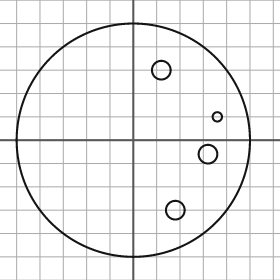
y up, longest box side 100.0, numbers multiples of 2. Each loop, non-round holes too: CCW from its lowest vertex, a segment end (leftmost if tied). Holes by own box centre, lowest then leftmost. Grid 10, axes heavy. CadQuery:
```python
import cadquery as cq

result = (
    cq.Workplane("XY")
    .moveTo(0.0, 0.0)
    .circle(50.0)
    .moveTo(18.0, -30.0)
    .circle(4.0)
    .moveTo(32.0, -6.0)
    .circle(4.0)
    .moveTo(36.0, 10.0)
    .circle(2.0)
    .moveTo(12.0, 30.0)
    .circle(4.0)
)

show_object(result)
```